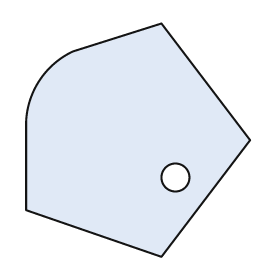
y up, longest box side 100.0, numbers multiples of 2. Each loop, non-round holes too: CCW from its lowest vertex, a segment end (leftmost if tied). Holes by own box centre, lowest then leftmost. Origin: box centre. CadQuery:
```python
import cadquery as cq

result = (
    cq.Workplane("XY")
    .moveTo(10.0, -50.0)
    .lineTo(48.0, 0.0)
    .lineTo(10.0, 50.0)
    .lineTo(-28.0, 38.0)
    .threePointArc((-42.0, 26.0), (-48.0, 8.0))
    .lineTo(-48.0, -30.0)
    .close()
    .moveTo(16.0, -16.0)
    .circle(6.0)
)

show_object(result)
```